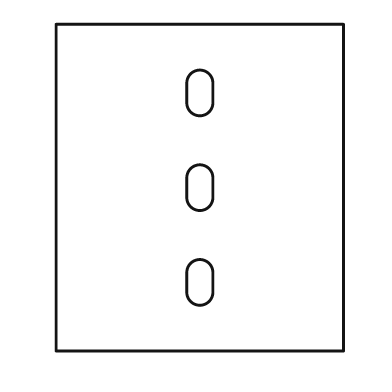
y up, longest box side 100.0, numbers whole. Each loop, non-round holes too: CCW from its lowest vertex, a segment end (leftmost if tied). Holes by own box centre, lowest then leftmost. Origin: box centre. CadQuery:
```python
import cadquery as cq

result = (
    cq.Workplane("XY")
    .moveTo(-44.0, -50.0)
    .lineTo(44.0, -50.0)
    .lineTo(44.0, 50.0)
    .lineTo(-44.0, 50.0)
    .close()
    .moveTo(-4.0, -32.0)
    .threePointArc((0.0, -36.0), (4.0, -32.0))
    .lineTo(4.0, -26.0)
    .threePointArc((0.0, -22.0), (-4.0, -26.0))
    .close()
    .moveTo(-4.0, -3.0)
    .threePointArc((0.0, -7.0), (4.0, -3.0))
    .lineTo(4.0, 3.0)
    .threePointArc((0.0, 7.0), (-4.0, 3.0))
    .close()
    .moveTo(-4.0, 26.0)
    .threePointArc((0.0, 22.0), (4.0, 26.0))
    .lineTo(4.0, 32.0)
    .threePointArc((0.0, 36.0), (-4.0, 32.0))
    .close()
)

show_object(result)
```